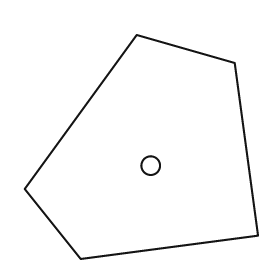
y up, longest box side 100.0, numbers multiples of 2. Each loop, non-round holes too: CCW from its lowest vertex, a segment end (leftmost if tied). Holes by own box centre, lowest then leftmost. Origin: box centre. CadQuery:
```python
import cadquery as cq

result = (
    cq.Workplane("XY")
    .moveTo(-26.0, -48.0)
    .lineTo(50.0, -38.0)
    .lineTo(40.0, 36.0)
    .lineTo(-2.0, 48.0)
    .lineTo(-50.0, -18.0)
    .close()
    .moveTo(4.0, -8.0)
    .circle(4.0)
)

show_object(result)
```